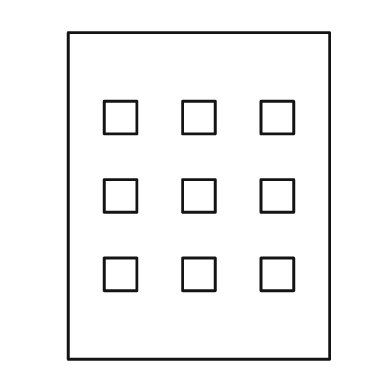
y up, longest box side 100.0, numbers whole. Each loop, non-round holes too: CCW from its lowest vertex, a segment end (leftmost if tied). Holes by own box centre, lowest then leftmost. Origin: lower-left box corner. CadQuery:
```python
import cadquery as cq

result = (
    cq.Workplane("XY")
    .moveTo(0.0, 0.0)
    .lineTo(80.0, 0.0)
    .lineTo(80.0, 100.0)
    .lineTo(0.0, 100.0)
    .close()
    .moveTo(11.0, 21.0)
    .lineTo(21.0, 21.0)
    .lineTo(21.0, 31.0)
    .lineTo(11.0, 31.0)
    .close()
    .moveTo(35.0, 21.0)
    .lineTo(45.0, 21.0)
    .lineTo(45.0, 31.0)
    .lineTo(35.0, 31.0)
    .close()
    .moveTo(59.0, 21.0)
    .lineTo(69.0, 21.0)
    .lineTo(69.0, 31.0)
    .lineTo(59.0, 31.0)
    .close()
    .moveTo(11.0, 45.0)
    .lineTo(21.0, 45.0)
    .lineTo(21.0, 55.0)
    .lineTo(11.0, 55.0)
    .close()
    .moveTo(35.0, 45.0)
    .lineTo(45.0, 45.0)
    .lineTo(45.0, 55.0)
    .lineTo(35.0, 55.0)
    .close()
    .moveTo(59.0, 45.0)
    .lineTo(69.0, 45.0)
    .lineTo(69.0, 55.0)
    .lineTo(59.0, 55.0)
    .close()
    .moveTo(11.0, 69.0)
    .lineTo(21.0, 69.0)
    .lineTo(21.0, 79.0)
    .lineTo(11.0, 79.0)
    .close()
    .moveTo(35.0, 69.0)
    .lineTo(45.0, 69.0)
    .lineTo(45.0, 79.0)
    .lineTo(35.0, 79.0)
    .close()
    .moveTo(59.0, 69.0)
    .lineTo(69.0, 69.0)
    .lineTo(69.0, 79.0)
    .lineTo(59.0, 79.0)
    .close()
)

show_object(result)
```